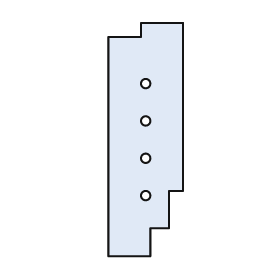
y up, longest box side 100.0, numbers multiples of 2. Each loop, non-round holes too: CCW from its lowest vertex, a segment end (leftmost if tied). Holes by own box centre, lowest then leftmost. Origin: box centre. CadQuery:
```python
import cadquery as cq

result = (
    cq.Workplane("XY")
    .moveTo(-16.0, -50.0)
    .lineTo(2.0, -50.0)
    .lineTo(2.0, -38.0)
    .lineTo(10.0, -38.0)
    .lineTo(10.0, -22.0)
    .lineTo(16.0, -22.0)
    .lineTo(16.0, 50.0)
    .lineTo(-2.0, 50.0)
    .lineTo(-2.0, 44.0)
    .lineTo(-16.0, 44.0)
    .close()
    .moveTo(0.0, -24.0)
    .circle(2.0)
    .moveTo(0.0, -8.0)
    .circle(2.0)
    .moveTo(0.0, 8.0)
    .circle(2.0)
    .moveTo(0.0, 24.0)
    .circle(2.0)
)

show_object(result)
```